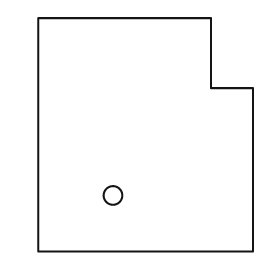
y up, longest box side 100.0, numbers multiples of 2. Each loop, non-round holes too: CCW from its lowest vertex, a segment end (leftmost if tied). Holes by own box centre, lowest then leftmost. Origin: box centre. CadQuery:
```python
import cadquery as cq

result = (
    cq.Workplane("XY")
    .moveTo(-46.0, -50.0)
    .lineTo(46.0, -50.0)
    .lineTo(46.0, 20.0)
    .lineTo(28.0, 20.0)
    .lineTo(28.0, 50.0)
    .lineTo(-46.0, 50.0)
    .close()
    .moveTo(-14.0, -26.0)
    .circle(4.0)
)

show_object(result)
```